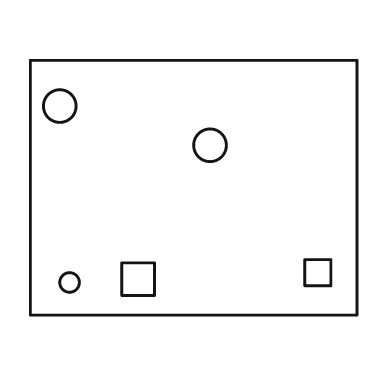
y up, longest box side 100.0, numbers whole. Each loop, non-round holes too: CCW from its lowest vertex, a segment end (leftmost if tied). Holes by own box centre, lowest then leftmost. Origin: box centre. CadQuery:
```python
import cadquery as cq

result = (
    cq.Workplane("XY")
    .moveTo(-50.0, -39.0)
    .lineTo(50.0, -39.0)
    .lineTo(50.0, 39.0)
    .lineTo(-50.0, 39.0)
    .close()
    .moveTo(-38.0, -29.0)
    .circle(3.0)
    .moveTo(-22.0, -33.0)
    .lineTo(-12.0, -33.0)
    .lineTo(-12.0, -23.0)
    .lineTo(-22.0, -23.0)
    .close()
    .moveTo(34.0, -30.0)
    .lineTo(42.0, -30.0)
    .lineTo(42.0, -22.0)
    .lineTo(34.0, -22.0)
    .close()
    .moveTo(5.0, 13.0)
    .circle(5.0)
    .moveTo(-41.0, 25.0)
    .circle(5.0)
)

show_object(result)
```